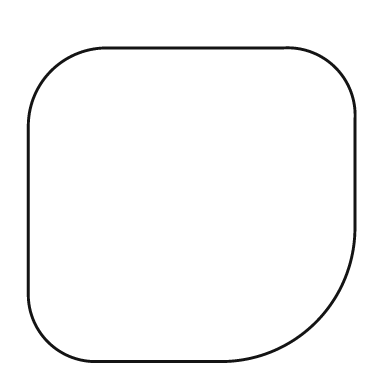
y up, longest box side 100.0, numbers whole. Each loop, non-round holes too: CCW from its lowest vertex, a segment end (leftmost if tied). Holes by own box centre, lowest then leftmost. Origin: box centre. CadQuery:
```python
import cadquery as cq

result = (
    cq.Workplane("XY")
    .moveTo(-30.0, -48.0)
    .lineTo(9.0, -48.0)
    .threePointArc((38.0, -36.0), (50.0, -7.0))
    .lineTo(50.0, 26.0)
    .threePointArc((44.0, 42.0), (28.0, 48.0))
    .lineTo(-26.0, 48.0)
    .threePointArc((-43.0, 41.0), (-50.0, 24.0))
    .lineTo(-50.0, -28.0)
    .threePointArc((-44.0, -42.0), (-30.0, -48.0))
    .close()
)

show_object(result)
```